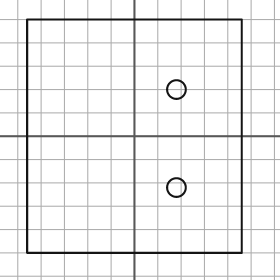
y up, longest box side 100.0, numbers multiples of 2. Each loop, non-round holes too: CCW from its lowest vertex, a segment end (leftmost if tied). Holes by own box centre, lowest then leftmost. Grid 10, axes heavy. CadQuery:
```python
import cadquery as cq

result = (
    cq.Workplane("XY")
    .moveTo(-46.0, -50.0)
    .lineTo(46.0, -50.0)
    .lineTo(46.0, 50.0)
    .lineTo(-46.0, 50.0)
    .close()
    .moveTo(18.0, -22.0)
    .circle(4.0)
    .moveTo(18.0, 20.0)
    .circle(4.0)
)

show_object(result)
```